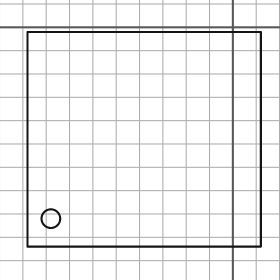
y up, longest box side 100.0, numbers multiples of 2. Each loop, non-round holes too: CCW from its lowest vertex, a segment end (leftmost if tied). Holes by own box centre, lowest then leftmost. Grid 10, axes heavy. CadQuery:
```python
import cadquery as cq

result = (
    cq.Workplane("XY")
    .moveTo(-88.0, -94.0)
    .lineTo(12.0, -94.0)
    .lineTo(12.0, -2.0)
    .lineTo(-88.0, -2.0)
    .close()
    .moveTo(-78.0, -82.0)
    .circle(4.0)
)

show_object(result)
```